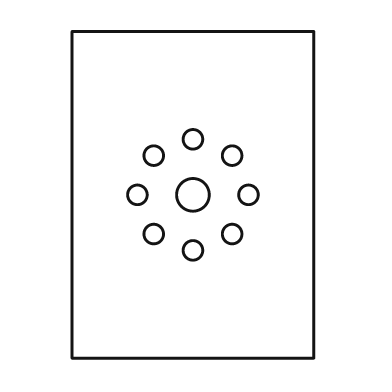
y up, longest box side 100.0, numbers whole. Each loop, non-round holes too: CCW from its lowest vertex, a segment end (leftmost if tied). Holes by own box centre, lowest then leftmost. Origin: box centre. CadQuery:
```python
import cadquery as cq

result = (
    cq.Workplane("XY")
    .moveTo(-37.0, -50.0)
    .lineTo(37.0, -50.0)
    .lineTo(37.0, 50.0)
    .lineTo(-37.0, 50.0)
    .close()
    .moveTo(0.0, -17.0)
    .circle(3.0)
    .moveTo(-12.0, -12.0)
    .circle(3.0)
    .moveTo(12.0, -12.0)
    .circle(3.0)
    .moveTo(-17.0, 0.0)
    .circle(3.0)
    .moveTo(0.0, 0.0)
    .circle(5.0)
    .moveTo(17.0, 0.0)
    .circle(3.0)
    .moveTo(-12.0, 12.0)
    .circle(3.0)
    .moveTo(12.0, 12.0)
    .circle(3.0)
    .moveTo(0.0, 17.0)
    .circle(3.0)
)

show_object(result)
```